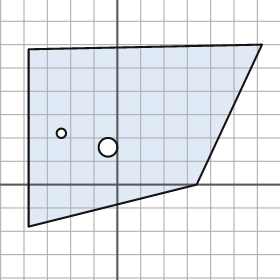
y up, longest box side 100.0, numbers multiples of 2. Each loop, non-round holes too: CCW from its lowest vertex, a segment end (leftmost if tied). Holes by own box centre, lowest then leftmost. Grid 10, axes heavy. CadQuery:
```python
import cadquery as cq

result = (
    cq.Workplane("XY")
    .moveTo(-38.0, -18.0)
    .lineTo(34.0, 0.0)
    .lineTo(62.0, 60.0)
    .lineTo(-38.0, 58.0)
    .close()
    .moveTo(-4.0, 16.0)
    .circle(4.0)
    .moveTo(-24.0, 22.0)
    .circle(2.0)
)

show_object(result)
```